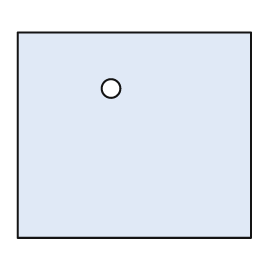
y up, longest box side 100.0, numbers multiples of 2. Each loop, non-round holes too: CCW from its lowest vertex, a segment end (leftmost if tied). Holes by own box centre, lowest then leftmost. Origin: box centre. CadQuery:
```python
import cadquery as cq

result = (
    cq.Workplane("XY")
    .moveTo(-50.0, -44.0)
    .lineTo(50.0, -44.0)
    .lineTo(50.0, 44.0)
    .lineTo(-50.0, 44.0)
    .close()
    .moveTo(-10.0, 20.0)
    .circle(4.0)
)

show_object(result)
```